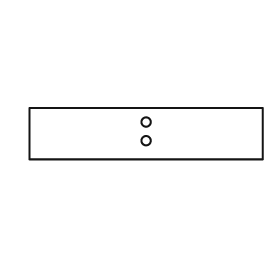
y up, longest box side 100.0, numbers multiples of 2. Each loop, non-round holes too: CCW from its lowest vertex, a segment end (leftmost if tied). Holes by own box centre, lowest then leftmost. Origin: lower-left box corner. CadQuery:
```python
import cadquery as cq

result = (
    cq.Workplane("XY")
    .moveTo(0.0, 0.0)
    .lineTo(100.0, 0.0)
    .lineTo(100.0, 22.0)
    .lineTo(0.0, 22.0)
    .close()
    .moveTo(50.0, 8.0)
    .circle(2.0)
    .moveTo(50.0, 16.0)
    .circle(2.0)
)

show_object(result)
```